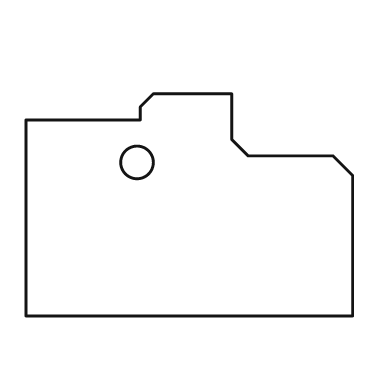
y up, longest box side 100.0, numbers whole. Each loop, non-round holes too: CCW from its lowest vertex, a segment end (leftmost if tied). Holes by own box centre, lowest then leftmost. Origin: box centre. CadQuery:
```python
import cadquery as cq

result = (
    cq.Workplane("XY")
    .moveTo(-50.0, -34.0)
    .lineTo(50.0, -34.0)
    .lineTo(50.0, 9.0)
    .lineTo(44.0, 15.0)
    .lineTo(18.0, 15.0)
    .lineTo(13.0, 20.0)
    .lineTo(13.0, 34.0)
    .lineTo(-11.0, 34.0)
    .lineTo(-15.0, 30.0)
    .lineTo(-15.0, 26.0)
    .lineTo(-50.0, 26.0)
    .close()
    .moveTo(-16.0, 13.0)
    .circle(5.0)
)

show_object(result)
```